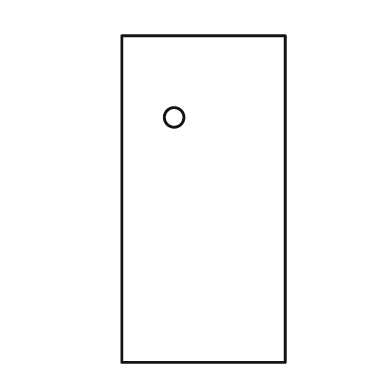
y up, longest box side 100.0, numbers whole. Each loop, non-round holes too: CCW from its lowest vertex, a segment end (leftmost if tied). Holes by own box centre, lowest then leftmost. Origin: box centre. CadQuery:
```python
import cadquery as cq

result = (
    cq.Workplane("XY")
    .moveTo(-25.0, -50.0)
    .lineTo(25.0, -50.0)
    .lineTo(25.0, 50.0)
    .lineTo(-25.0, 50.0)
    .close()
    .moveTo(-9.0, 25.0)
    .circle(3.0)
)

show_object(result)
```